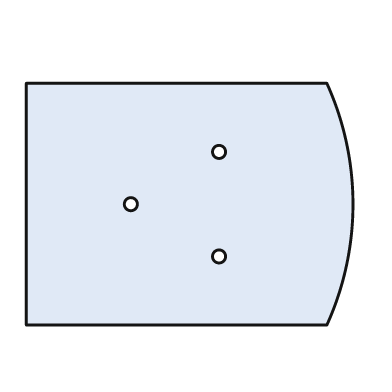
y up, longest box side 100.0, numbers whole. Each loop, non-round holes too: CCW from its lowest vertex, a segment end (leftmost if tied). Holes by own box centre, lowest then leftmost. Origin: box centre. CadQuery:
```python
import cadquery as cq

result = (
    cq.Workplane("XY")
    .moveTo(-50.0, -37.0)
    .lineTo(42.0, -37.0)
    .threePointArc((50.0, 0.0), (42.0, 37.0))
    .lineTo(-50.0, 37.0)
    .close()
    .moveTo(9.0, -16.0)
    .circle(2.0)
    .moveTo(-18.0, 0.0)
    .circle(2.0)
    .moveTo(9.0, 16.0)
    .circle(2.0)
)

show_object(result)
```